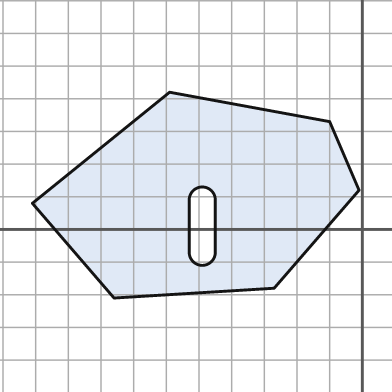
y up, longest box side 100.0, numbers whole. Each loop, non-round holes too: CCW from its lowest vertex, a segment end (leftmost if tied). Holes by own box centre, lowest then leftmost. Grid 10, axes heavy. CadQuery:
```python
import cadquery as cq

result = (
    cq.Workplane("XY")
    .moveTo(-76.0, -21.0)
    .lineTo(-27.0, -18.0)
    .lineTo(-1.0, 12.0)
    .lineTo(-10.0, 33.0)
    .lineTo(-59.0, 42.0)
    .lineTo(-101.0, 8.0)
    .close()
    .moveTo(-53.0, -7.0)
    .threePointArc((-49.0, -11.0), (-45.0, -7.0))
    .lineTo(-45.0, 9.0)
    .threePointArc((-49.0, 13.0), (-53.0, 9.0))
    .close()
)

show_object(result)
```